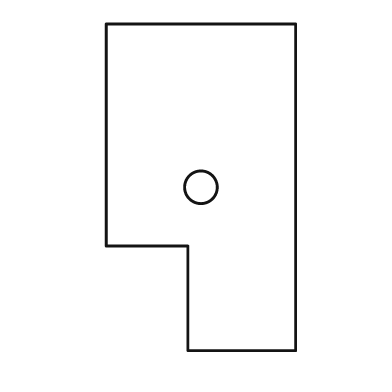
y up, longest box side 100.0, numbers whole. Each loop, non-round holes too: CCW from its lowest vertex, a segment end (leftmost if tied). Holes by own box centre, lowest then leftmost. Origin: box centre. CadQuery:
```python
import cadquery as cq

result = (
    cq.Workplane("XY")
    .moveTo(-4.0, -50.0)
    .lineTo(29.0, -50.0)
    .lineTo(29.0, 50.0)
    .lineTo(-29.0, 50.0)
    .lineTo(-29.0, -18.0)
    .lineTo(-4.0, -18.0)
    .close()
    .moveTo(0.0, 0.0)
    .circle(5.0)
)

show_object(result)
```